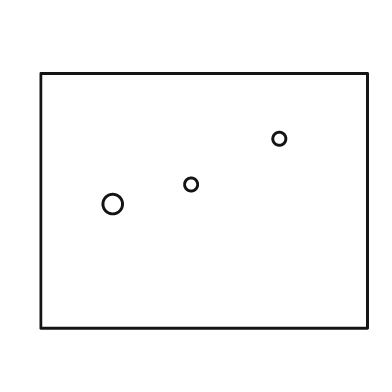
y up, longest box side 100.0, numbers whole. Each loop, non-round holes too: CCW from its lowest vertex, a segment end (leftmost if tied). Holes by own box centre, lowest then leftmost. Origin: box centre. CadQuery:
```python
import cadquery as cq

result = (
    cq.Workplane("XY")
    .moveTo(-50.0, -39.0)
    .lineTo(50.0, -39.0)
    .lineTo(50.0, 39.0)
    .lineTo(-50.0, 39.0)
    .close()
    .moveTo(-28.0, -1.0)
    .circle(3.0)
    .moveTo(-4.0, 5.0)
    .circle(2.0)
    .moveTo(23.0, 19.0)
    .circle(2.0)
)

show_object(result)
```